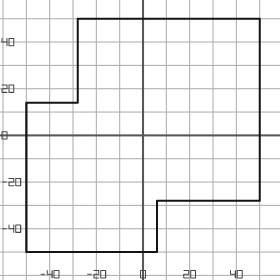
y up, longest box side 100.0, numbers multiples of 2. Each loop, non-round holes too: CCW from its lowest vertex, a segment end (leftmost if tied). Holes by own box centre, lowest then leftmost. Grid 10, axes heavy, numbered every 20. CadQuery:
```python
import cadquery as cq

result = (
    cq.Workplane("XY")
    .moveTo(-50.0, -50.0)
    .lineTo(6.0, -50.0)
    .lineTo(6.0, -28.0)
    .lineTo(50.0, -28.0)
    .lineTo(50.0, 50.0)
    .lineTo(-28.0, 50.0)
    .lineTo(-28.0, 14.0)
    .lineTo(-50.0, 14.0)
    .close()
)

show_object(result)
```